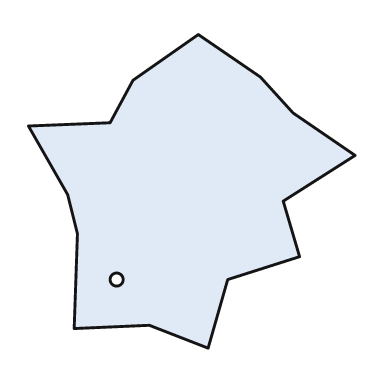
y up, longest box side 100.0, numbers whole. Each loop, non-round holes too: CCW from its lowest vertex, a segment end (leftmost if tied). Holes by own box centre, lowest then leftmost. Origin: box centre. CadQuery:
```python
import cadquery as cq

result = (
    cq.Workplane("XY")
    .moveTo(5.0, -48.0)
    .lineTo(11.0, -27.0)
    .lineTo(33.0, -20.0)
    .lineTo(28.0, -3.0)
    .lineTo(50.0, 11.0)
    .lineTo(31.0, 24.0)
    .lineTo(21.0, 35.0)
    .lineTo(2.0, 48.0)
    .lineTo(-18.0, 34.0)
    .lineTo(-25.0, 21.0)
    .lineTo(-50.0, 20.0)
    .lineTo(-38.0, -1.0)
    .lineTo(-35.0, -13.0)
    .lineTo(-36.0, -42.0)
    .lineTo(-13.0, -41.0)
    .close()
    .moveTo(-23.0, -27.0)
    .circle(2.0)
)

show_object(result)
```